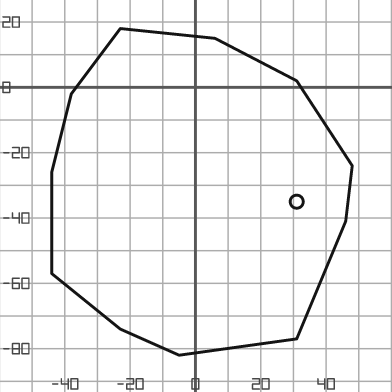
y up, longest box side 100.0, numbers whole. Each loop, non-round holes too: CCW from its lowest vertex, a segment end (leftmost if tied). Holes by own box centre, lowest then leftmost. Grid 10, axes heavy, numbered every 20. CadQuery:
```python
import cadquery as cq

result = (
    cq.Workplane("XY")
    .moveTo(-5.0, -82.0)
    .lineTo(31.0, -77.0)
    .lineTo(46.0, -41.0)
    .lineTo(48.0, -24.0)
    .lineTo(31.0, 2.0)
    .lineTo(6.0, 15.0)
    .lineTo(-23.0, 18.0)
    .lineTo(-38.0, -2.0)
    .lineTo(-44.0, -26.0)
    .lineTo(-44.0, -57.0)
    .lineTo(-23.0, -74.0)
    .close()
    .moveTo(31.0, -35.0)
    .circle(2.0)
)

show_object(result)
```